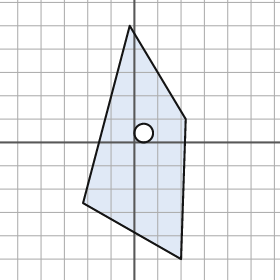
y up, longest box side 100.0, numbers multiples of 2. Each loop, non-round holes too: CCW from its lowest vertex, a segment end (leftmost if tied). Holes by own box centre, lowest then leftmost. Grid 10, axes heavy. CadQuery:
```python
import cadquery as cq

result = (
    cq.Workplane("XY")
    .moveTo(20.0, -50.0)
    .lineTo(22.0, 10.0)
    .lineTo(-2.0, 50.0)
    .lineTo(-22.0, -26.0)
    .close()
    .moveTo(4.0, 4.0)
    .circle(4.0)
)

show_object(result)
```